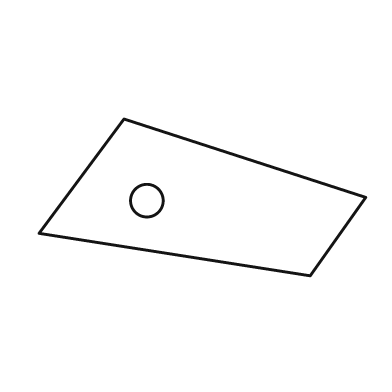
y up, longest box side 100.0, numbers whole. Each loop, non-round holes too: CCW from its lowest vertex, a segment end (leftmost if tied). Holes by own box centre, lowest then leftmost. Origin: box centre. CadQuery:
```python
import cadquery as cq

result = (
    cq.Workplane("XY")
    .moveTo(33.0, -24.0)
    .lineTo(50.0, 0.0)
    .lineTo(-24.0, 24.0)
    .lineTo(-50.0, -11.0)
    .close()
    .moveTo(-17.0, -1.0)
    .circle(5.0)
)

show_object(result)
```